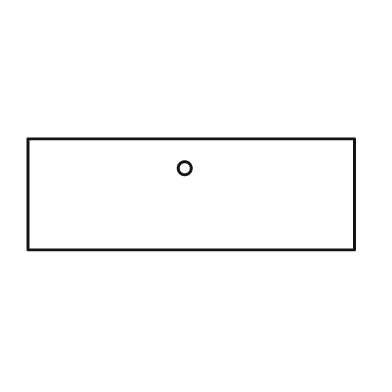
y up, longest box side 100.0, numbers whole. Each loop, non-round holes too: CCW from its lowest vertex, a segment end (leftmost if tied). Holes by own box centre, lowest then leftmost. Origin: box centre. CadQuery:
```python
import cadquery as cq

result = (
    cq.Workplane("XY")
    .moveTo(-50.0, -17.0)
    .lineTo(50.0, -17.0)
    .lineTo(50.0, 17.0)
    .lineTo(-50.0, 17.0)
    .close()
    .moveTo(-2.0, 8.0)
    .circle(2.0)
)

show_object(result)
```